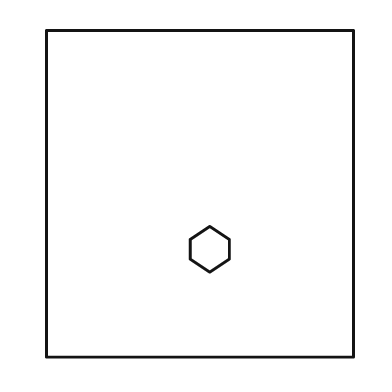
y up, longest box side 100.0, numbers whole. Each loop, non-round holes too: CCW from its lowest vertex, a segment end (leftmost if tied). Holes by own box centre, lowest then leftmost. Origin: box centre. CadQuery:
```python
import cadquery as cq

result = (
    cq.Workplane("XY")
    .moveTo(-47.0, -50.0)
    .lineTo(47.0, -50.0)
    .lineTo(47.0, 50.0)
    .lineTo(-47.0, 50.0)
    .close()
    .moveTo(3.0, -24.0)
    .lineTo(9.0, -20.0)
    .lineTo(9.0, -14.0)
    .lineTo(3.0, -10.0)
    .lineTo(-3.0, -14.0)
    .lineTo(-3.0, -20.0)
    .close()
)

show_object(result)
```